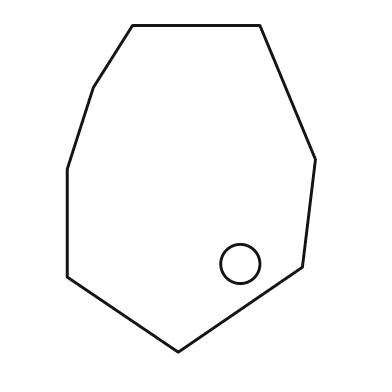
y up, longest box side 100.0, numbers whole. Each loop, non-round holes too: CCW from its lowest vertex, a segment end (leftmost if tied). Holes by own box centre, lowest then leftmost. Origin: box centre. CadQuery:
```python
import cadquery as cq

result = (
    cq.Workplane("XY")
    .moveTo(-4.0, -50.0)
    .lineTo(34.0, -24.0)
    .lineTo(38.0, 9.0)
    .lineTo(21.0, 50.0)
    .lineTo(-18.0, 50.0)
    .lineTo(-30.0, 31.0)
    .lineTo(-38.0, 6.0)
    .lineTo(-38.0, -27.0)
    .close()
    .moveTo(15.0, -23.0)
    .circle(6.0)
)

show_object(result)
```